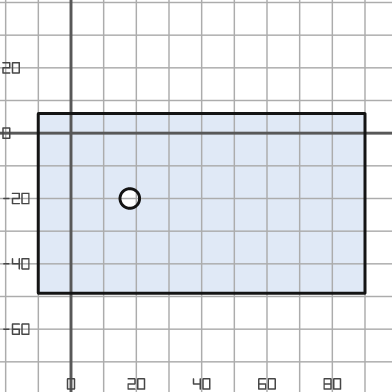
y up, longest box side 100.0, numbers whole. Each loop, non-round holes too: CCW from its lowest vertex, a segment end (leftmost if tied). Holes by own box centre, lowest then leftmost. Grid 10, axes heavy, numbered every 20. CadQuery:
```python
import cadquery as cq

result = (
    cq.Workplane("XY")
    .moveTo(-10.0, -49.0)
    .lineTo(90.0, -49.0)
    .lineTo(90.0, 6.0)
    .lineTo(-10.0, 6.0)
    .close()
    .moveTo(18.0, -20.0)
    .circle(3.0)
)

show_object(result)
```